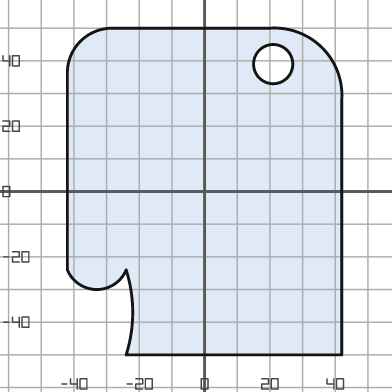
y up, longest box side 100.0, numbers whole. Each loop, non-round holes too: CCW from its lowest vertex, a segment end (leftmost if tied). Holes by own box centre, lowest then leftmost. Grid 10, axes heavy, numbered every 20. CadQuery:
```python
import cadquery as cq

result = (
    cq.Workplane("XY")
    .moveTo(-24.0, -50.0)
    .lineTo(42.0, -50.0)
    .lineTo(42.0, 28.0)
    .threePointArc((36.0, 44.0), (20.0, 50.0))
    .lineTo(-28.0, 50.0)
    .threePointArc((-38.0, 46.0), (-42.0, 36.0))
    .lineTo(-42.0, -24.0)
    .threePointArc((-33.0, -30.0), (-24.0, -24.0))
    .threePointArc((-22.0, -37.0), (-24.0, -50.0))
    .close()
    .moveTo(21.0, 39.0)
    .circle(6.0)
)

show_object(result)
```